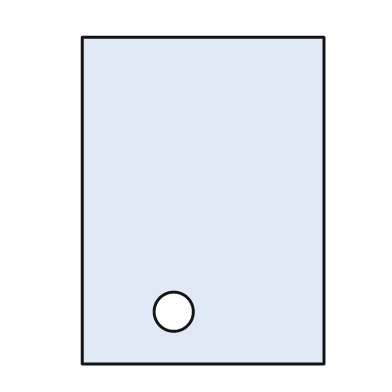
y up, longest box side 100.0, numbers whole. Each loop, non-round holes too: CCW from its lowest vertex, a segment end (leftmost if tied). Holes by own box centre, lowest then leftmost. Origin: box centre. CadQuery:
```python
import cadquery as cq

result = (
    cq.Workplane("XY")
    .moveTo(-37.0, -50.0)
    .lineTo(37.0, -50.0)
    .lineTo(37.0, 50.0)
    .lineTo(-37.0, 50.0)
    .close()
    .moveTo(-9.0, -34.0)
    .circle(6.0)
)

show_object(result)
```